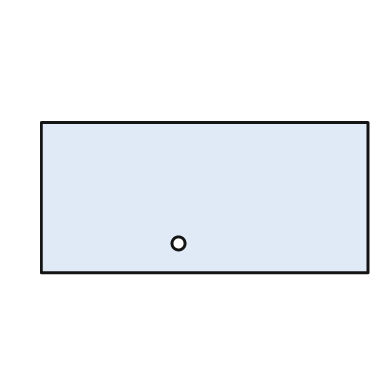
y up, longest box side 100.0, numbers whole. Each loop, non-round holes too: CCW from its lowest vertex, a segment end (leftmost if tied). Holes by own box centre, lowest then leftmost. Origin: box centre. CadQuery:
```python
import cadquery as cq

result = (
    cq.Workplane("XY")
    .moveTo(-50.0, -23.0)
    .lineTo(50.0, -23.0)
    .lineTo(50.0, 23.0)
    .lineTo(-50.0, 23.0)
    .close()
    .moveTo(-8.0, -14.0)
    .circle(2.0)
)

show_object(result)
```